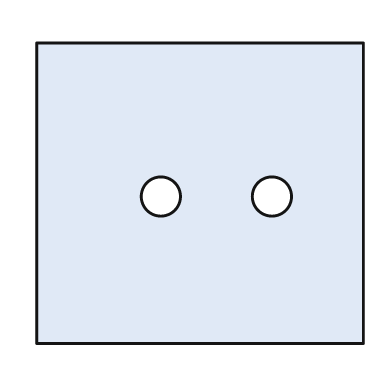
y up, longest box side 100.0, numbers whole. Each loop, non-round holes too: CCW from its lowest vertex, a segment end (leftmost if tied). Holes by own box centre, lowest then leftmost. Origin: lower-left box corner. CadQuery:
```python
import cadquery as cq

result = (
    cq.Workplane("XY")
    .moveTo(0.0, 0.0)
    .lineTo(100.0, 0.0)
    .lineTo(100.0, 92.0)
    .lineTo(0.0, 92.0)
    .close()
    .moveTo(38.0, 45.0)
    .circle(6.0)
    .moveTo(72.0, 45.0)
    .circle(6.0)
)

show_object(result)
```